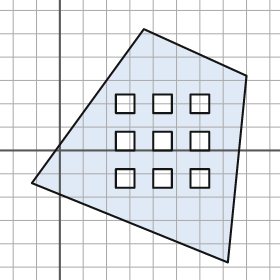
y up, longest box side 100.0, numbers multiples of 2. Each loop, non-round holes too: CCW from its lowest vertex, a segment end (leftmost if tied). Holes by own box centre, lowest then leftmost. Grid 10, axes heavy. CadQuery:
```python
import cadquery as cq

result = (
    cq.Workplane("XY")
    .moveTo(72.0, -48.0)
    .lineTo(80.0, 32.0)
    .lineTo(36.0, 52.0)
    .lineTo(-12.0, -14.0)
    .close()
    .moveTo(24.0, -16.0)
    .lineTo(32.0, -16.0)
    .lineTo(32.0, -8.0)
    .lineTo(24.0, -8.0)
    .close()
    .moveTo(40.0, -16.0)
    .lineTo(48.0, -16.0)
    .lineTo(48.0, -8.0)
    .lineTo(40.0, -8.0)
    .close()
    .moveTo(56.0, -16.0)
    .lineTo(64.0, -16.0)
    .lineTo(64.0, -8.0)
    .lineTo(56.0, -8.0)
    .close()
    .moveTo(24.0, 0.0)
    .lineTo(32.0, 0.0)
    .lineTo(32.0, 8.0)
    .lineTo(24.0, 8.0)
    .close()
    .moveTo(40.0, 0.0)
    .lineTo(48.0, 0.0)
    .lineTo(48.0, 8.0)
    .lineTo(40.0, 8.0)
    .close()
    .moveTo(56.0, 0.0)
    .lineTo(64.0, 0.0)
    .lineTo(64.0, 8.0)
    .lineTo(56.0, 8.0)
    .close()
    .moveTo(24.0, 16.0)
    .lineTo(32.0, 16.0)
    .lineTo(32.0, 24.0)
    .lineTo(24.0, 24.0)
    .close()
    .moveTo(40.0, 16.0)
    .lineTo(48.0, 16.0)
    .lineTo(48.0, 24.0)
    .lineTo(40.0, 24.0)
    .close()
    .moveTo(56.0, 16.0)
    .lineTo(64.0, 16.0)
    .lineTo(64.0, 24.0)
    .lineTo(56.0, 24.0)
    .close()
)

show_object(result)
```